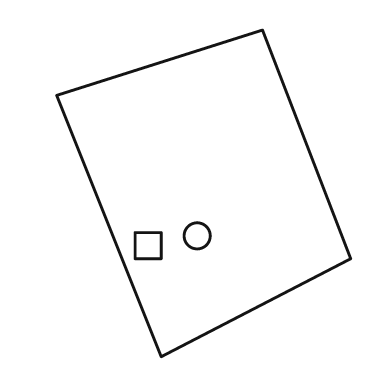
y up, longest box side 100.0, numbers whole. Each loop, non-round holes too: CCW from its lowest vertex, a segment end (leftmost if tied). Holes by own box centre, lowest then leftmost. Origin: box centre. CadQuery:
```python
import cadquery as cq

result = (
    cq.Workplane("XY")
    .moveTo(-13.0, -50.0)
    .lineTo(45.0, -20.0)
    .lineTo(18.0, 50.0)
    .lineTo(-45.0, 30.0)
    .close()
    .moveTo(-21.0, -20.0)
    .lineTo(-13.0, -20.0)
    .lineTo(-13.0, -12.0)
    .lineTo(-21.0, -12.0)
    .close()
    .moveTo(-2.0, -13.0)
    .circle(4.0)
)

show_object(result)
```